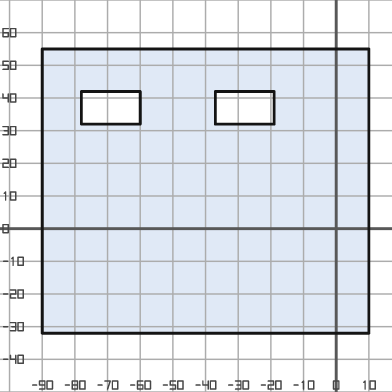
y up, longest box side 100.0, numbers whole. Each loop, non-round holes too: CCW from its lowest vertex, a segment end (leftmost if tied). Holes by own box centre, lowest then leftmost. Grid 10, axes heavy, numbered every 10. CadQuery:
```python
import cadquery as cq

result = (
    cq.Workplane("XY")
    .moveTo(-90.0, -32.0)
    .lineTo(10.0, -32.0)
    .lineTo(10.0, 55.0)
    .lineTo(-90.0, 55.0)
    .close()
    .moveTo(-78.0, 32.0)
    .lineTo(-60.0, 32.0)
    .lineTo(-60.0, 42.0)
    .lineTo(-78.0, 42.0)
    .close()
    .moveTo(-37.0, 32.0)
    .lineTo(-19.0, 32.0)
    .lineTo(-19.0, 42.0)
    .lineTo(-37.0, 42.0)
    .close()
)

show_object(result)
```